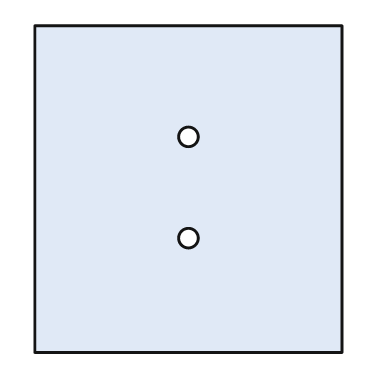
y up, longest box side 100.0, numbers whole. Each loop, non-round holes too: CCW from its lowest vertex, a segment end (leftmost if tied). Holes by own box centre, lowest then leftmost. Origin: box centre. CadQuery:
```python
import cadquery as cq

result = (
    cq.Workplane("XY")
    .moveTo(-47.0, -50.0)
    .lineTo(47.0, -50.0)
    .lineTo(47.0, 50.0)
    .lineTo(-47.0, 50.0)
    .close()
    .moveTo(0.0, -15.0)
    .circle(3.0)
    .moveTo(0.0, 16.0)
    .circle(3.0)
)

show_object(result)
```